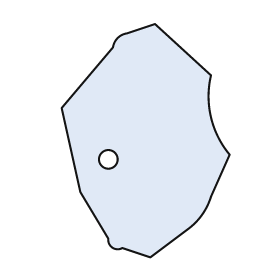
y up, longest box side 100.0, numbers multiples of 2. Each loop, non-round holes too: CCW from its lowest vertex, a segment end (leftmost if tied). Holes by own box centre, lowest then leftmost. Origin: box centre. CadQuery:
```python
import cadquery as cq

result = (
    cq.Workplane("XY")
    .moveTo(2.0, -50.0)
    .lineTo(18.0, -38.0)
    .threePointArc((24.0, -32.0), (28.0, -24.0))
    .lineTo(36.0, -6.0)
    .threePointArc((28.0, 10.0), (28.0, 28.0))
    .lineTo(4.0, 50.0)
    .lineTo(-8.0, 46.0)
    .threePointArc((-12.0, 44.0), (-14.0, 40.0))
    .lineTo(-36.0, 14.0)
    .lineTo(-28.0, -22.0)
    .lineTo(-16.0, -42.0)
    .threePointArc((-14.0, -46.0), (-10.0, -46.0))
    .close()
    .moveTo(-16.0, -8.0)
    .circle(4.0)
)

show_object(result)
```